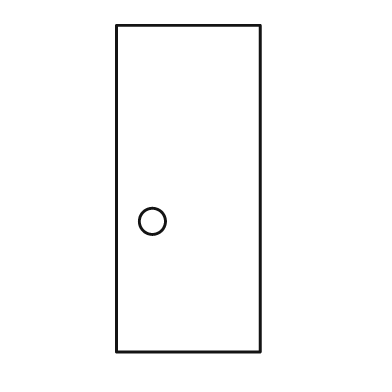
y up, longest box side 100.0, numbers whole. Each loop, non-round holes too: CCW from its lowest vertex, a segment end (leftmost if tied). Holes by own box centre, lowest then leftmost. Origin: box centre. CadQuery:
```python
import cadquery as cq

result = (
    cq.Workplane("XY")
    .moveTo(-22.0, -50.0)
    .lineTo(22.0, -50.0)
    .lineTo(22.0, 50.0)
    .lineTo(-22.0, 50.0)
    .close()
    .moveTo(-11.0, -10.0)
    .circle(4.0)
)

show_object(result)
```